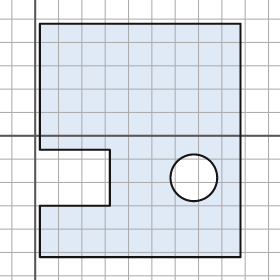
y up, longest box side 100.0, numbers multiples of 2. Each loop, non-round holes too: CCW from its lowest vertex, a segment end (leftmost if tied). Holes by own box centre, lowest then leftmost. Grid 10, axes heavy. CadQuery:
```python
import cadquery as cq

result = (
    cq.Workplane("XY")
    .moveTo(2.0, -52.0)
    .lineTo(88.0, -52.0)
    .lineTo(88.0, 48.0)
    .lineTo(2.0, 48.0)
    .lineTo(2.0, -6.0)
    .lineTo(32.0, -6.0)
    .lineTo(32.0, -30.0)
    .lineTo(2.0, -30.0)
    .close()
    .moveTo(68.0, -18.0)
    .circle(10.0)
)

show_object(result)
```